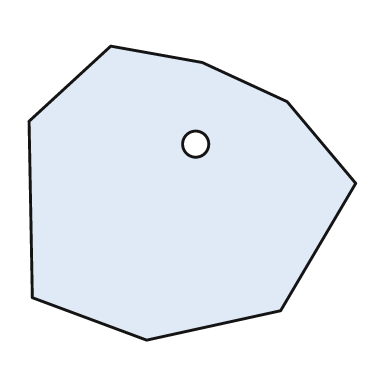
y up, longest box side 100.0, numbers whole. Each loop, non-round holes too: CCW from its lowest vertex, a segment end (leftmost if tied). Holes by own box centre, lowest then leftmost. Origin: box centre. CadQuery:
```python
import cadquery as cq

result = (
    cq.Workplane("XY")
    .moveTo(-14.0, -45.0)
    .lineTo(27.0, -36.0)
    .lineTo(50.0, 3.0)
    .lineTo(29.0, 28.0)
    .lineTo(3.0, 40.0)
    .lineTo(-25.0, 45.0)
    .lineTo(-50.0, 22.0)
    .lineTo(-49.0, -32.0)
    .close()
    .moveTo(1.0, 15.0)
    .circle(4.0)
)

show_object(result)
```